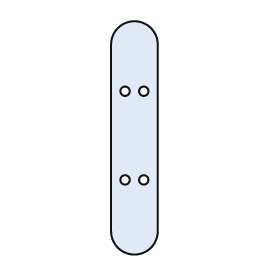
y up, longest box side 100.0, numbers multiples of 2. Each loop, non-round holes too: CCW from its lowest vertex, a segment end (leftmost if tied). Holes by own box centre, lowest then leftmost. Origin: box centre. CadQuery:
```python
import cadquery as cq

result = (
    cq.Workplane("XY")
    .moveTo(-10.0, -40.0)
    .threePointArc((0.0, -50.0), (10.0, -40.0))
    .lineTo(10.0, 40.0)
    .threePointArc((0.0, 50.0), (-10.0, 40.0))
    .close()
    .moveTo(-4.0, -18.0)
    .circle(2.0)
    .moveTo(4.0, -18.0)
    .circle(2.0)
    .moveTo(-4.0, 20.0)
    .circle(2.0)
    .moveTo(4.0, 20.0)
    .circle(2.0)
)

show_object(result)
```